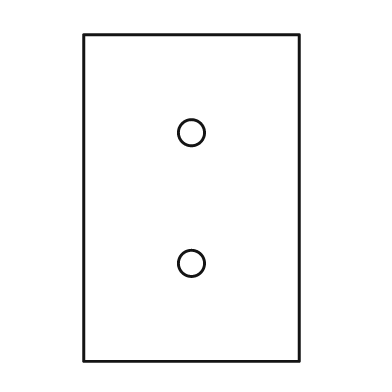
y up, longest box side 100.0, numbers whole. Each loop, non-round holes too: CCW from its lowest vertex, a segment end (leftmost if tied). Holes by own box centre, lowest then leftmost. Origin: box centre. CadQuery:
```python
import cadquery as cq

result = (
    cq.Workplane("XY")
    .moveTo(-33.0, -50.0)
    .lineTo(33.0, -50.0)
    .lineTo(33.0, 50.0)
    .lineTo(-33.0, 50.0)
    .close()
    .moveTo(0.0, -20.0)
    .circle(4.0)
    .moveTo(0.0, 20.0)
    .circle(4.0)
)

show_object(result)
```